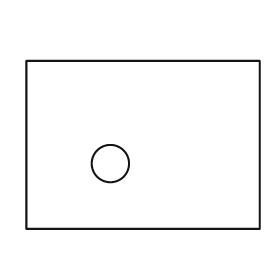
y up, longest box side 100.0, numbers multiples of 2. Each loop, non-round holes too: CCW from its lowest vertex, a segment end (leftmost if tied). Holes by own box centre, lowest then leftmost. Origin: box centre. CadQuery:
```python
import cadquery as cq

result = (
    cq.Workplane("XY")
    .moveTo(-50.0, -36.0)
    .lineTo(50.0, -36.0)
    .lineTo(50.0, 36.0)
    .lineTo(-50.0, 36.0)
    .close()
    .moveTo(-14.0, -8.0)
    .circle(8.0)
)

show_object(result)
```